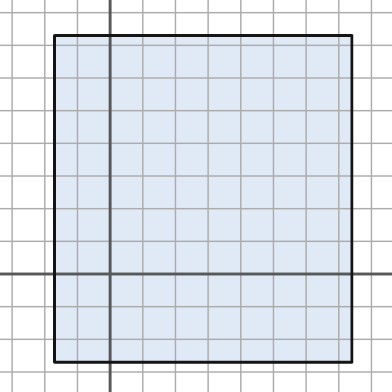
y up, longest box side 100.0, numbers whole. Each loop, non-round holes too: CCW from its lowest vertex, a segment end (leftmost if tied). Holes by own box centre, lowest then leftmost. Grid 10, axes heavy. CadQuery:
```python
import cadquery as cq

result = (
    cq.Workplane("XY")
    .moveTo(-17.0, -27.0)
    .lineTo(74.0, -27.0)
    .lineTo(74.0, 73.0)
    .lineTo(-17.0, 73.0)
    .close()
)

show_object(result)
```